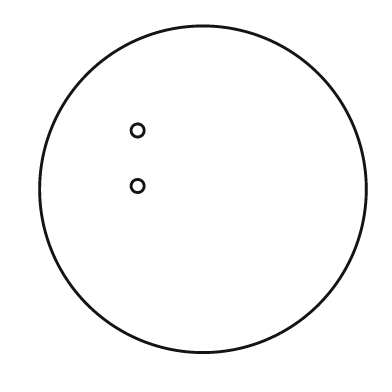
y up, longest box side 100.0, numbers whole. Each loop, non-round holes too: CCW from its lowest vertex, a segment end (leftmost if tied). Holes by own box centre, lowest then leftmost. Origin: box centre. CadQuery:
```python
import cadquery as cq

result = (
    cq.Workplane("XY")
    .moveTo(0.0, 0.0)
    .circle(50.0)
    .moveTo(-20.0, 1.0)
    .circle(2.0)
    .moveTo(-20.0, 18.0)
    .circle(2.0)
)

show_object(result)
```